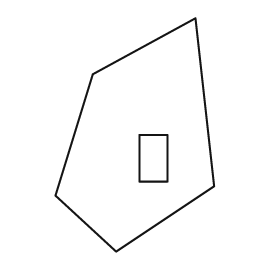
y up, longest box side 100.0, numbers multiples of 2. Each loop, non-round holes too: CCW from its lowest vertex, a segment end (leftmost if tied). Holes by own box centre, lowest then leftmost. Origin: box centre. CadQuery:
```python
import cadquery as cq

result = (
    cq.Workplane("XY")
    .moveTo(-8.0, -50.0)
    .lineTo(34.0, -22.0)
    .lineTo(26.0, 50.0)
    .lineTo(-18.0, 26.0)
    .lineTo(-34.0, -26.0)
    .close()
    .moveTo(2.0, -20.0)
    .lineTo(14.0, -20.0)
    .lineTo(14.0, 0.0)
    .lineTo(2.0, 0.0)
    .close()
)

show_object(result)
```